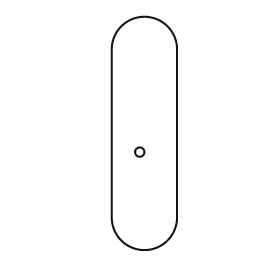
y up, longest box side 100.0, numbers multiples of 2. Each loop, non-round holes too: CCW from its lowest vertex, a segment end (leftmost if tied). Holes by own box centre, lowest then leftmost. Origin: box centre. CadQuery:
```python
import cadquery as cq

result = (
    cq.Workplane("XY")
    .moveTo(-14.0, -36.0)
    .threePointArc((0.0, -50.0), (14.0, -36.0))
    .lineTo(14.0, 36.0)
    .threePointArc((0.0, 50.0), (-14.0, 36.0))
    .close()
    .moveTo(-2.0, -8.0)
    .circle(2.0)
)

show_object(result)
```